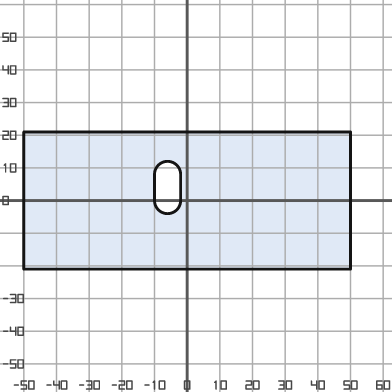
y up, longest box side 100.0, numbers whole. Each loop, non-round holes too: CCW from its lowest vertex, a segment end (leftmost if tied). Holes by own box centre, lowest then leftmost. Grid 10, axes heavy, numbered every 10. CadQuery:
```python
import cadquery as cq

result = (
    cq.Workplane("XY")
    .moveTo(-50.0, -21.0)
    .lineTo(50.0, -21.0)
    .lineTo(50.0, 21.0)
    .lineTo(-50.0, 21.0)
    .close()
    .moveTo(-10.0, 0.0)
    .threePointArc((-6.0, -4.0), (-2.0, 0.0))
    .lineTo(-2.0, 8.0)
    .threePointArc((-6.0, 12.0), (-10.0, 8.0))
    .close()
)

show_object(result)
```